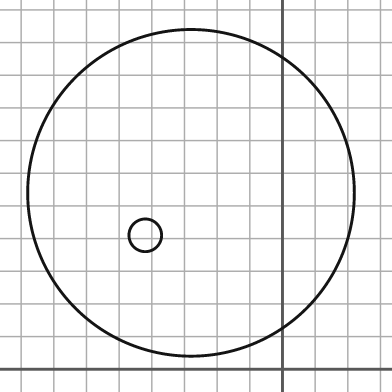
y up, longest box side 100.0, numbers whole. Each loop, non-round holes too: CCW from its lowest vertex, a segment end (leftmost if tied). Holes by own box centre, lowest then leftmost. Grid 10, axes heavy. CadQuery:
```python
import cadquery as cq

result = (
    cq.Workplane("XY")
    .moveTo(-28.0, 54.0)
    .circle(50.0)
    .moveTo(-42.0, 41.0)
    .circle(5.0)
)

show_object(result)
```